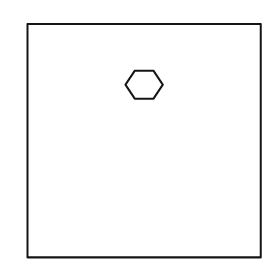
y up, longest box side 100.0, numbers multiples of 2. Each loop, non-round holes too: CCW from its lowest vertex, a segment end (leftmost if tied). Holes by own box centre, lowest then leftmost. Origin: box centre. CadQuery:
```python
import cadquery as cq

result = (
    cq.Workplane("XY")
    .moveTo(-50.0, -50.0)
    .lineTo(50.0, -50.0)
    .lineTo(50.0, 50.0)
    .lineTo(-50.0, 50.0)
    .close()
    .moveTo(-4.0, 18.0)
    .lineTo(4.0, 18.0)
    .lineTo(8.0, 24.0)
    .lineTo(4.0, 30.0)
    .lineTo(-4.0, 30.0)
    .lineTo(-8.0, 24.0)
    .close()
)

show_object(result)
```